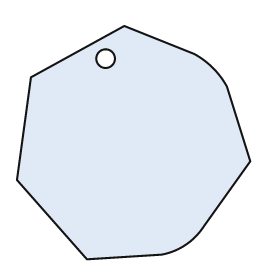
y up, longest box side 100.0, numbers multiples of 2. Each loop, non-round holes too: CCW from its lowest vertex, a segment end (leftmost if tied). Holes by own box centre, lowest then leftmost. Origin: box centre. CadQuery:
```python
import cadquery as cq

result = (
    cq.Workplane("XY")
    .moveTo(-20.0, -50.0)
    .lineTo(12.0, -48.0)
    .threePointArc((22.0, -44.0), (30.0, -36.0))
    .lineTo(50.0, -8.0)
    .lineTo(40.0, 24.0)
    .threePointArc((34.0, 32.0), (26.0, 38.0))
    .lineTo(-4.0, 50.0)
    .lineTo(-44.0, 28.0)
    .lineTo(-50.0, -16.0)
    .close()
    .moveTo(-12.0, 36.0)
    .circle(4.0)
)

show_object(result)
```